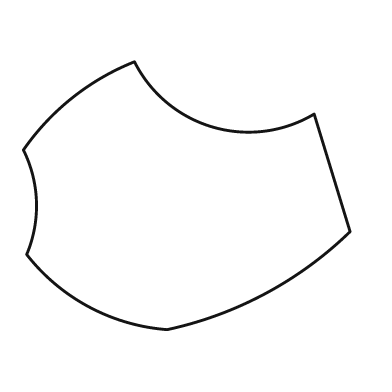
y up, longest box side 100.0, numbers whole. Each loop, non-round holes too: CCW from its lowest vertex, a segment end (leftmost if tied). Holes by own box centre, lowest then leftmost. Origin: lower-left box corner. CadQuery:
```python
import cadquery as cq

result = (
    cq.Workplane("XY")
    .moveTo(44.0, 0.0)
    .threePointArc((74.0, 11.0), (100.0, 30.0))
    .lineTo(89.0, 66.0)
    .threePointArc((58.0, 62.0), (34.0, 82.0))
    .threePointArc((15.0, 71.0), (0.0, 55.0))
    .threePointArc((4.0, 39.0), (1.0, 23.0))
    .threePointArc((20.0, 7.0), (44.0, 0.0))
    .close()
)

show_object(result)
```